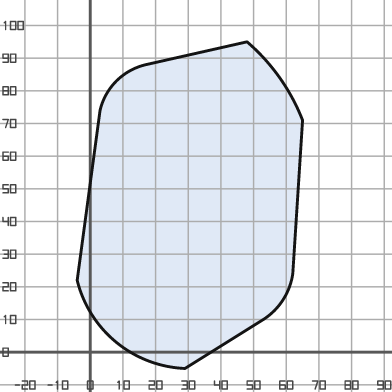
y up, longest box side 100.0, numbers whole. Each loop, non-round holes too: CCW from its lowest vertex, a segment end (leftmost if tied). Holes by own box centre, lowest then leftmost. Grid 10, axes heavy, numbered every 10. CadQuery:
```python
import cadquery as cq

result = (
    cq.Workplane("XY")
    .moveTo(29.0, -5.0)
    .lineTo(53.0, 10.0)
    .threePointArc((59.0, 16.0), (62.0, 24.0))
    .lineTo(65.0, 71.0)
    .threePointArc((58.0, 84.0), (48.0, 95.0))
    .lineTo(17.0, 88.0)
    .threePointArc((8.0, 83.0), (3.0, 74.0))
    .lineTo(-4.0, 22.0)
    .threePointArc((8.0, 3.0), (29.0, -5.0))
    .close()
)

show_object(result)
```